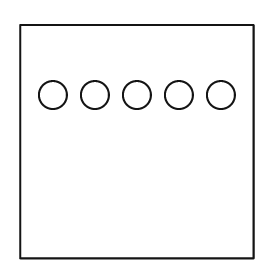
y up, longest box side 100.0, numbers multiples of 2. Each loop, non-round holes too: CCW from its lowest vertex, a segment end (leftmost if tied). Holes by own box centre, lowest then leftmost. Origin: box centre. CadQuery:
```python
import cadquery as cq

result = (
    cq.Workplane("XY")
    .moveTo(-50.0, -50.0)
    .lineTo(50.0, -50.0)
    .lineTo(50.0, 50.0)
    .lineTo(-50.0, 50.0)
    .close()
    .moveTo(-36.0, 20.0)
    .circle(6.0)
    .moveTo(-18.0, 20.0)
    .circle(6.0)
    .moveTo(0.0, 20.0)
    .circle(6.0)
    .moveTo(18.0, 20.0)
    .circle(6.0)
    .moveTo(36.0, 20.0)
    .circle(6.0)
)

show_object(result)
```